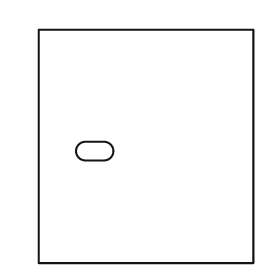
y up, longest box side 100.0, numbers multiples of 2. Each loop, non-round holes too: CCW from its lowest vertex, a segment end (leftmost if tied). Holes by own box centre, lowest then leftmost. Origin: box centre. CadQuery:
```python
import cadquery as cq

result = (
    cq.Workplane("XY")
    .moveTo(-46.0, -50.0)
    .lineTo(46.0, -50.0)
    .lineTo(46.0, 50.0)
    .lineTo(-46.0, 50.0)
    .close()
    .moveTo(-26.0, -6.0)
    .lineTo(-18.0, -6.0)
    .threePointArc((-14.0, -2.0), (-18.0, 2.0))
    .lineTo(-26.0, 2.0)
    .threePointArc((-30.0, -2.0), (-26.0, -6.0))
    .close()
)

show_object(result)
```